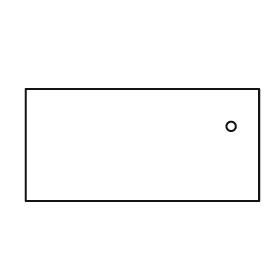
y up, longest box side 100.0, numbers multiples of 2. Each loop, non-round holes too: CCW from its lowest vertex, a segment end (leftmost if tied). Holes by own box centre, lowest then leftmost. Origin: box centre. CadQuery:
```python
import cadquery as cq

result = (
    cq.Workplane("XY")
    .moveTo(-50.0, -24.0)
    .lineTo(50.0, -24.0)
    .lineTo(50.0, 24.0)
    .lineTo(-50.0, 24.0)
    .close()
    .moveTo(38.0, 8.0)
    .circle(2.0)
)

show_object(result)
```